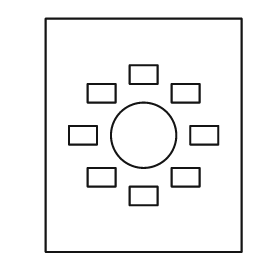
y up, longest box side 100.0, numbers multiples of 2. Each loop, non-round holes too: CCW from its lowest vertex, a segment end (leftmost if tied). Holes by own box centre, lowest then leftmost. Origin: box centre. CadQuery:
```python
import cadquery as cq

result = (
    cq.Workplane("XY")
    .moveTo(-42.0, -50.0)
    .lineTo(42.0, -50.0)
    .lineTo(42.0, 50.0)
    .lineTo(-42.0, 50.0)
    .close()
    .moveTo(-6.0, -30.0)
    .lineTo(6.0, -30.0)
    .lineTo(6.0, -22.0)
    .lineTo(-6.0, -22.0)
    .close()
    .moveTo(-24.0, -22.0)
    .lineTo(-12.0, -22.0)
    .lineTo(-12.0, -14.0)
    .lineTo(-24.0, -14.0)
    .close()
    .moveTo(12.0, -22.0)
    .lineTo(24.0, -22.0)
    .lineTo(24.0, -14.0)
    .lineTo(12.0, -14.0)
    .close()
    .moveTo(-32.0, -4.0)
    .lineTo(-20.0, -4.0)
    .lineTo(-20.0, 4.0)
    .lineTo(-32.0, 4.0)
    .close()
    .moveTo(0.0, 0.0)
    .circle(14.0)
    .moveTo(20.0, -4.0)
    .lineTo(32.0, -4.0)
    .lineTo(32.0, 4.0)
    .lineTo(20.0, 4.0)
    .close()
    .moveTo(-24.0, 14.0)
    .lineTo(-12.0, 14.0)
    .lineTo(-12.0, 22.0)
    .lineTo(-24.0, 22.0)
    .close()
    .moveTo(12.0, 14.0)
    .lineTo(24.0, 14.0)
    .lineTo(24.0, 22.0)
    .lineTo(12.0, 22.0)
    .close()
    .moveTo(-6.0, 22.0)
    .lineTo(6.0, 22.0)
    .lineTo(6.0, 30.0)
    .lineTo(-6.0, 30.0)
    .close()
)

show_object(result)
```